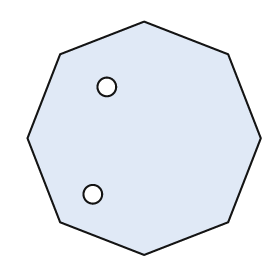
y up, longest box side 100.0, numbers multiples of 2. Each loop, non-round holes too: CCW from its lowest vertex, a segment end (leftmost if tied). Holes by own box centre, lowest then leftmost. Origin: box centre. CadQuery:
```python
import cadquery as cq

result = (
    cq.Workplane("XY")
    .moveTo(0.0, -50.0)
    .lineTo(36.0, -36.0)
    .lineTo(50.0, 0.0)
    .lineTo(36.0, 36.0)
    .lineTo(0.0, 50.0)
    .lineTo(-36.0, 36.0)
    .lineTo(-50.0, 0.0)
    .lineTo(-36.0, -36.0)
    .close()
    .moveTo(-22.0, -24.0)
    .circle(4.0)
    .moveTo(-16.0, 22.0)
    .circle(4.0)
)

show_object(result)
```